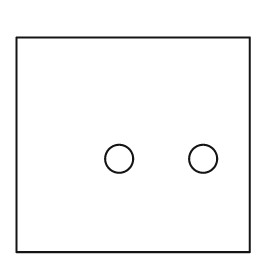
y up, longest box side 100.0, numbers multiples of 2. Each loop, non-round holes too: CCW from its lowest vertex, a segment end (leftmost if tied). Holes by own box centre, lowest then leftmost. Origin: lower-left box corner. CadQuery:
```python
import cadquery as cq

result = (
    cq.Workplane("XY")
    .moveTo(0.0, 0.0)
    .lineTo(100.0, 0.0)
    .lineTo(100.0, 92.0)
    .lineTo(0.0, 92.0)
    .close()
    .moveTo(44.0, 40.0)
    .circle(6.0)
    .moveTo(80.0, 40.0)
    .circle(6.0)
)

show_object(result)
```